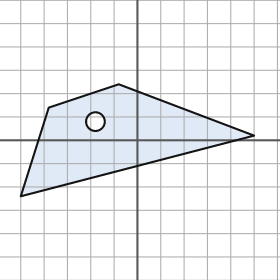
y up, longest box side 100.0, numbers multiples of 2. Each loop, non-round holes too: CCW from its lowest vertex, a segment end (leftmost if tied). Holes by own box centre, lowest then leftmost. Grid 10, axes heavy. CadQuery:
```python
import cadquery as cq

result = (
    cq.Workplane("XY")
    .moveTo(-50.0, -24.0)
    .lineTo(50.0, 2.0)
    .lineTo(-8.0, 24.0)
    .lineTo(-38.0, 14.0)
    .close()
    .moveTo(-18.0, 8.0)
    .circle(4.0)
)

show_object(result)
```